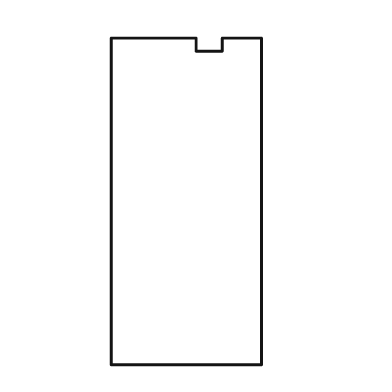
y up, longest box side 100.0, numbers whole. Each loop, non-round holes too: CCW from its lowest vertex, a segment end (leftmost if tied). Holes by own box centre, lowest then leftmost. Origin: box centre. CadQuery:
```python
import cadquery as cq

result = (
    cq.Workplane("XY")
    .moveTo(-23.0, -50.0)
    .lineTo(23.0, -50.0)
    .lineTo(23.0, 50.0)
    .lineTo(11.0, 50.0)
    .lineTo(11.0, 46.0)
    .lineTo(3.0, 46.0)
    .lineTo(3.0, 50.0)
    .lineTo(-23.0, 50.0)
    .close()
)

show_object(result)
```